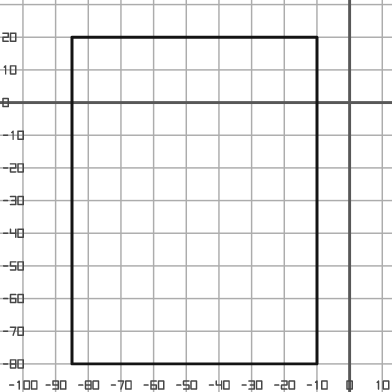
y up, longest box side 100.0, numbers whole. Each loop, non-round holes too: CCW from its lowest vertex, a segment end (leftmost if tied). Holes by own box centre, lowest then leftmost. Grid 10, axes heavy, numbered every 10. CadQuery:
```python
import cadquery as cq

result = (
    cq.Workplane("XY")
    .moveTo(-85.0, -80.0)
    .lineTo(-10.0, -80.0)
    .lineTo(-10.0, 20.0)
    .lineTo(-85.0, 20.0)
    .close()
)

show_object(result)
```